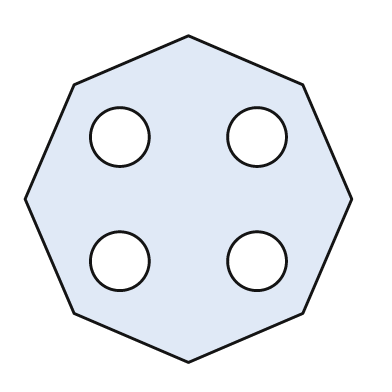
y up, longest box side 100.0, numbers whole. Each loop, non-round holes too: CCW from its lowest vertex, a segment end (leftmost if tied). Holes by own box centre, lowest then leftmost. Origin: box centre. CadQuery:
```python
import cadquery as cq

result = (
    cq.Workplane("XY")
    .moveTo(0.0, -50.0)
    .lineTo(35.0, -35.0)
    .lineTo(50.0, 0.0)
    .lineTo(35.0, 35.0)
    .lineTo(0.0, 50.0)
    .lineTo(-35.0, 35.0)
    .lineTo(-50.0, 0.0)
    .lineTo(-35.0, -35.0)
    .close()
    .moveTo(-21.0, -19.0)
    .circle(9.0)
    .moveTo(21.0, -19.0)
    .circle(9.0)
    .moveTo(-21.0, 19.0)
    .circle(9.0)
    .moveTo(21.0, 19.0)
    .circle(9.0)
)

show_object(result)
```